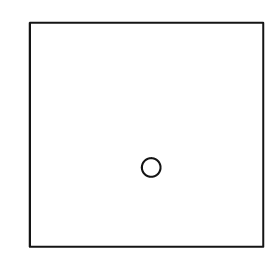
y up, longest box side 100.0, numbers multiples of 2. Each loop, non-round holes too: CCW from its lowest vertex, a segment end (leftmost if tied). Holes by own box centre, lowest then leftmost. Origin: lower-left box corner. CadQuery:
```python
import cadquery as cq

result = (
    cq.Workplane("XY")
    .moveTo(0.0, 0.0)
    .lineTo(100.0, 0.0)
    .lineTo(100.0, 96.0)
    .lineTo(0.0, 96.0)
    .close()
    .moveTo(52.0, 34.0)
    .circle(4.0)
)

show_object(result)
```